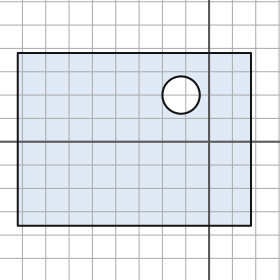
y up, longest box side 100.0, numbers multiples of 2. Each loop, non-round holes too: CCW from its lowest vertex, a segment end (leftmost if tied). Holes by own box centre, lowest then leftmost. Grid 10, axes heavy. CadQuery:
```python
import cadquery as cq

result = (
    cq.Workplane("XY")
    .moveTo(-82.0, -36.0)
    .lineTo(18.0, -36.0)
    .lineTo(18.0, 38.0)
    .lineTo(-82.0, 38.0)
    .close()
    .moveTo(-12.0, 20.0)
    .circle(8.0)
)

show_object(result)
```